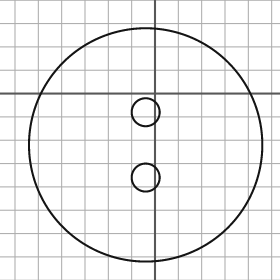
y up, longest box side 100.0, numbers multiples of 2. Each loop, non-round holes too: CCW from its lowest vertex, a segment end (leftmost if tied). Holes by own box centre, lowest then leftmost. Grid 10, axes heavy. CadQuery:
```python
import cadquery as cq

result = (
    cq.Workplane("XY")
    .moveTo(-4.0, -22.0)
    .circle(50.0)
    .moveTo(-4.0, -36.0)
    .circle(6.0)
    .moveTo(-4.0, -8.0)
    .circle(6.0)
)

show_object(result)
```